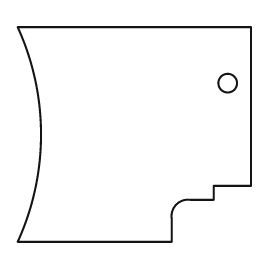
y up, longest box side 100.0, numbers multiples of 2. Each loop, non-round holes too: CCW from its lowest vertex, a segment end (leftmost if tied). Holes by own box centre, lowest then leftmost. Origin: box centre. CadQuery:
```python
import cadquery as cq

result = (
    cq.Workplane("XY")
    .moveTo(-50.0, -46.0)
    .lineTo(16.0, -46.0)
    .lineTo(16.0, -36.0)
    .threePointArc((18.0, -30.0), (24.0, -28.0))
    .lineTo(34.0, -28.0)
    .lineTo(34.0, -22.0)
    .lineTo(50.0, -22.0)
    .lineTo(50.0, 46.0)
    .lineTo(-50.0, 46.0)
    .threePointArc((-40.0, 0.0), (-50.0, -46.0))
    .close()
    .moveTo(40.0, 22.0)
    .circle(4.0)
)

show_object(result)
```